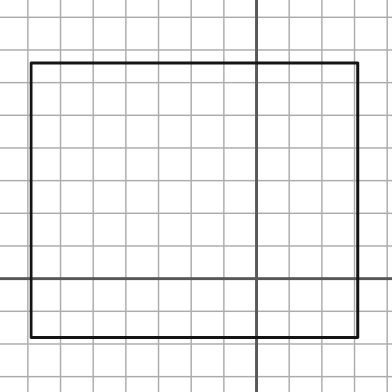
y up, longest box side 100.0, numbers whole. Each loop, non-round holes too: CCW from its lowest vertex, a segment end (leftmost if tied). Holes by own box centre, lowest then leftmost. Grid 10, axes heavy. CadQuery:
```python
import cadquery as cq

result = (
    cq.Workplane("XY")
    .moveTo(-69.0, -18.0)
    .lineTo(31.0, -18.0)
    .lineTo(31.0, 66.0)
    .lineTo(-69.0, 66.0)
    .close()
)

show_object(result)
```